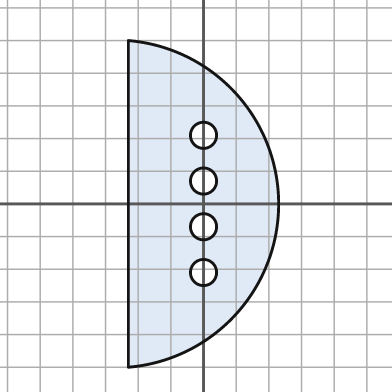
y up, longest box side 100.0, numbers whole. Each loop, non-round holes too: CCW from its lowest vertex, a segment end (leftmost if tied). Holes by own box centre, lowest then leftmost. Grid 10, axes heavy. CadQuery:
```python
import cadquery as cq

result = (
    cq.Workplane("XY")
    .moveTo(-23.0, -50.0)
    .threePointArc((23.0, 0.0), (-23.0, 50.0))
    .close()
    .moveTo(0.0, -21.0)
    .circle(4.0)
    .moveTo(0.0, -7.0)
    .circle(4.0)
    .moveTo(0.0, 7.0)
    .circle(4.0)
    .moveTo(0.0, 21.0)
    .circle(4.0)
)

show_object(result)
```